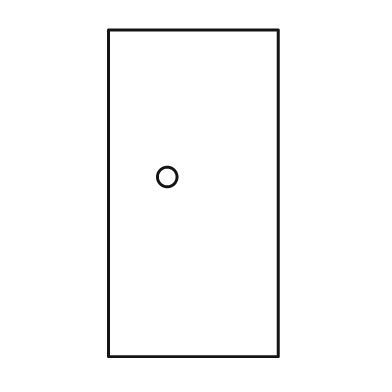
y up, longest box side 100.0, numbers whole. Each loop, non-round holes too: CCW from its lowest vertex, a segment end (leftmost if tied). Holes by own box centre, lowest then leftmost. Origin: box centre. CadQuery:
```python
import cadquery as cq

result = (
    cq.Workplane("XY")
    .moveTo(-26.0, -50.0)
    .lineTo(26.0, -50.0)
    .lineTo(26.0, 50.0)
    .lineTo(-26.0, 50.0)
    .close()
    .moveTo(-8.0, 5.0)
    .circle(3.0)
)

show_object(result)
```